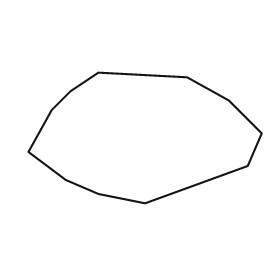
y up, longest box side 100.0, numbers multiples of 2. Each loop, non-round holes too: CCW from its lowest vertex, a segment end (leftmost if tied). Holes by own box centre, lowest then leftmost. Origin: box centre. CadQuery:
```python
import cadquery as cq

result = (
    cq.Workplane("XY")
    .moveTo(0.0, -28.0)
    .lineTo(44.0, -12.0)
    .lineTo(50.0, 2.0)
    .lineTo(36.0, 16.0)
    .lineTo(18.0, 26.0)
    .lineTo(-20.0, 28.0)
    .lineTo(-32.0, 20.0)
    .lineTo(-40.0, 12.0)
    .lineTo(-50.0, -6.0)
    .lineTo(-34.0, -18.0)
    .lineTo(-20.0, -24.0)
    .close()
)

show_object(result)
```